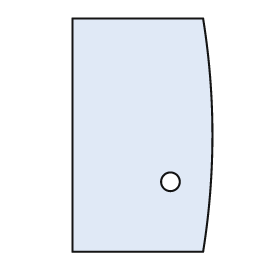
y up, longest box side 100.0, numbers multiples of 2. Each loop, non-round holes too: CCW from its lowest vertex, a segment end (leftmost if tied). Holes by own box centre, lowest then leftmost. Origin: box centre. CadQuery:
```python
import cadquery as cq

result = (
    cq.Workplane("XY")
    .moveTo(-30.0, -50.0)
    .lineTo(26.0, -50.0)
    .threePointArc((30.0, 0.0), (26.0, 50.0))
    .lineTo(-30.0, 50.0)
    .close()
    .moveTo(12.0, -20.0)
    .circle(4.0)
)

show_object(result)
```